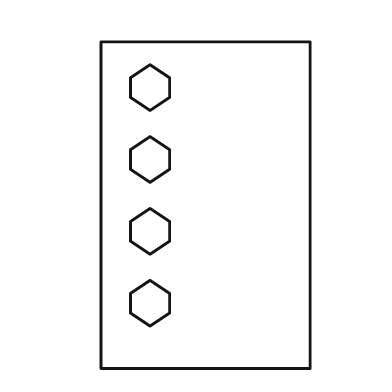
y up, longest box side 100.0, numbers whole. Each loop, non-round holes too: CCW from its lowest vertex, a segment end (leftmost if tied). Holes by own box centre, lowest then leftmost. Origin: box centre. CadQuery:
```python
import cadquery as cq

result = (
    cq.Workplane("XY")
    .moveTo(-32.0, -50.0)
    .lineTo(32.0, -50.0)
    .lineTo(32.0, 50.0)
    .lineTo(-32.0, 50.0)
    .close()
    .moveTo(-17.0, -37.0)
    .lineTo(-11.0, -33.0)
    .lineTo(-11.0, -27.0)
    .lineTo(-17.0, -23.0)
    .lineTo(-23.0, -27.0)
    .lineTo(-23.0, -33.0)
    .close()
    .moveTo(-17.0, -15.0)
    .lineTo(-11.0, -11.0)
    .lineTo(-11.0, -5.0)
    .lineTo(-17.0, -1.0)
    .lineTo(-23.0, -5.0)
    .lineTo(-23.0, -11.0)
    .close()
    .moveTo(-17.0, 7.0)
    .lineTo(-11.0, 11.0)
    .lineTo(-11.0, 17.0)
    .lineTo(-17.0, 21.0)
    .lineTo(-23.0, 17.0)
    .lineTo(-23.0, 11.0)
    .close()
    .moveTo(-17.0, 29.0)
    .lineTo(-11.0, 33.0)
    .lineTo(-11.0, 39.0)
    .lineTo(-17.0, 43.0)
    .lineTo(-23.0, 39.0)
    .lineTo(-23.0, 33.0)
    .close()
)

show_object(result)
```